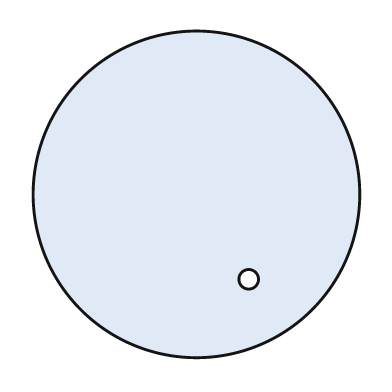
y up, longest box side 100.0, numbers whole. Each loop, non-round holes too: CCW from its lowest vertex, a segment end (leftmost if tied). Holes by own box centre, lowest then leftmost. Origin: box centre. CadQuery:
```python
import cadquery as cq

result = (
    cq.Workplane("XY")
    .moveTo(0.0, 0.0)
    .circle(50.0)
    .moveTo(16.0, -26.0)
    .circle(3.0)
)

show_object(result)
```